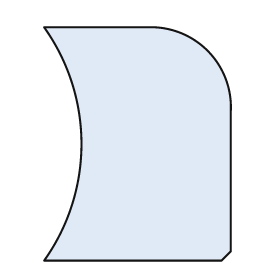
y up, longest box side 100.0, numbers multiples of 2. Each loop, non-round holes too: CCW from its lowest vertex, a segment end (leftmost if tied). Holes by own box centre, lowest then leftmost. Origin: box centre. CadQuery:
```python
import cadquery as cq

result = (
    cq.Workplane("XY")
    .moveTo(-40.0, -50.0)
    .lineTo(36.0, -50.0)
    .lineTo(40.0, -46.0)
    .lineTo(40.0, 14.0)
    .threePointArc((30.0, 40.0), (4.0, 50.0))
    .lineTo(-40.0, 50.0)
    .threePointArc((-24.0, 0.0), (-40.0, -50.0))
    .close()
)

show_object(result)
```